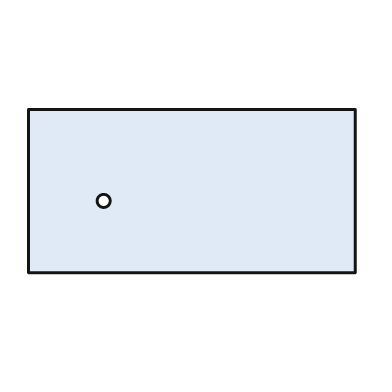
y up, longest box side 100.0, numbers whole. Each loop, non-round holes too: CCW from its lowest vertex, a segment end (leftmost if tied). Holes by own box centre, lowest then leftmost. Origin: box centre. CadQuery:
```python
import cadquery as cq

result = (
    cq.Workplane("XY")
    .moveTo(-50.0, -25.0)
    .lineTo(50.0, -25.0)
    .lineTo(50.0, 25.0)
    .lineTo(-50.0, 25.0)
    .close()
    .moveTo(-27.0, -3.0)
    .circle(2.0)
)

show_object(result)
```